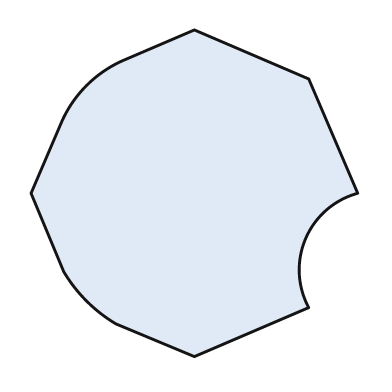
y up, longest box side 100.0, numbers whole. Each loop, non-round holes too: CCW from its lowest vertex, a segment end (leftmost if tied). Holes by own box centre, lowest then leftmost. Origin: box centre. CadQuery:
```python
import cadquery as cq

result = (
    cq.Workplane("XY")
    .moveTo(0.0, -50.0)
    .lineTo(35.0, -35.0)
    .threePointArc((34.0, -14.0), (50.0, 0.0))
    .lineTo(35.0, 35.0)
    .lineTo(0.0, 50.0)
    .lineTo(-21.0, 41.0)
    .threePointArc((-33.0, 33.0), (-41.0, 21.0))
    .lineTo(-50.0, 0.0)
    .lineTo(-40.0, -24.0)
    .threePointArc((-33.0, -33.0), (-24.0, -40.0))
    .close()
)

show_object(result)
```